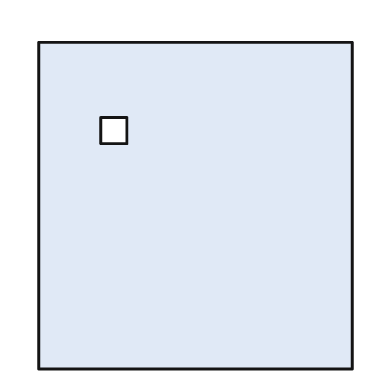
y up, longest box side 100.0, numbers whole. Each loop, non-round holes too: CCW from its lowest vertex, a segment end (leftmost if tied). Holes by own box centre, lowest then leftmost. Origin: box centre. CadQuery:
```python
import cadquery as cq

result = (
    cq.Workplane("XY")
    .moveTo(-48.0, -50.0)
    .lineTo(48.0, -50.0)
    .lineTo(48.0, 50.0)
    .lineTo(-48.0, 50.0)
    .close()
    .moveTo(-29.0, 19.0)
    .lineTo(-21.0, 19.0)
    .lineTo(-21.0, 27.0)
    .lineTo(-29.0, 27.0)
    .close()
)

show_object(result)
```